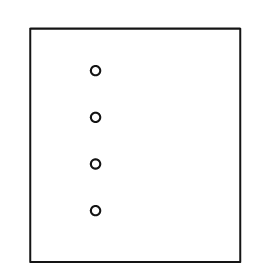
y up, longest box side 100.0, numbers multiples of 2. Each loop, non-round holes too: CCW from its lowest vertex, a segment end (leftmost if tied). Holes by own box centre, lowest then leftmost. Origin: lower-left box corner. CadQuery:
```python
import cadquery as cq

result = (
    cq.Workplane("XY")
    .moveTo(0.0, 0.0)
    .lineTo(90.0, 0.0)
    .lineTo(90.0, 100.0)
    .lineTo(0.0, 100.0)
    .close()
    .moveTo(28.0, 22.0)
    .circle(2.0)
    .moveTo(28.0, 42.0)
    .circle(2.0)
    .moveTo(28.0, 62.0)
    .circle(2.0)
    .moveTo(28.0, 82.0)
    .circle(2.0)
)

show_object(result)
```